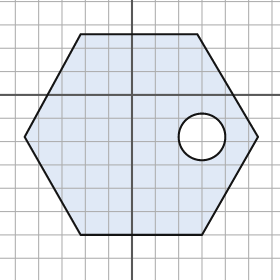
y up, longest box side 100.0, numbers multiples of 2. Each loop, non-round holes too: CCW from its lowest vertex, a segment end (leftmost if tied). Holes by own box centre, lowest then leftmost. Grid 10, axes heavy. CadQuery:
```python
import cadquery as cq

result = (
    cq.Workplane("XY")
    .moveTo(-22.0, -60.0)
    .lineTo(30.0, -60.0)
    .lineTo(54.0, -18.0)
    .lineTo(28.0, 26.0)
    .lineTo(-22.0, 26.0)
    .lineTo(-46.0, -18.0)
    .close()
    .moveTo(30.0, -18.0)
    .circle(10.0)
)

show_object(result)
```